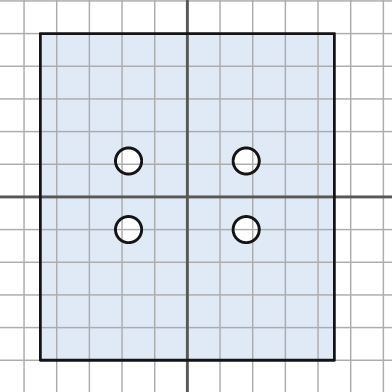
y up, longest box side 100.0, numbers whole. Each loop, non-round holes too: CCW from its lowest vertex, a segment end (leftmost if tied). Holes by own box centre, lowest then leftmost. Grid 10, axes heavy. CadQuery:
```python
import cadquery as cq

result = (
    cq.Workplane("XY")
    .moveTo(-45.0, -50.0)
    .lineTo(45.0, -50.0)
    .lineTo(45.0, 50.0)
    .lineTo(-45.0, 50.0)
    .close()
    .moveTo(-18.0, -10.0)
    .circle(4.0)
    .moveTo(18.0, -10.0)
    .circle(4.0)
    .moveTo(-18.0, 11.0)
    .circle(4.0)
    .moveTo(18.0, 11.0)
    .circle(4.0)
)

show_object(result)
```